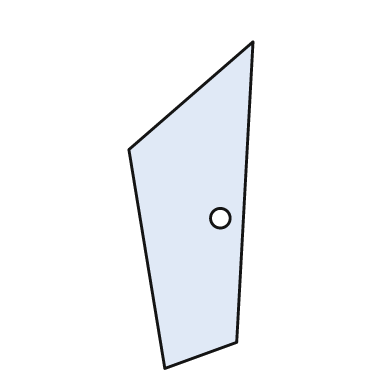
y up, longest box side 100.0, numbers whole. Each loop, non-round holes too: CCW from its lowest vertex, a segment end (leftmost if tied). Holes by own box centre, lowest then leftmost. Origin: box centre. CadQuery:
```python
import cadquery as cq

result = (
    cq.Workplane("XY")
    .moveTo(-8.0, -50.0)
    .lineTo(14.0, -42.0)
    .lineTo(19.0, 50.0)
    .lineTo(-19.0, 17.0)
    .close()
    .moveTo(9.0, -4.0)
    .circle(3.0)
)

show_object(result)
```